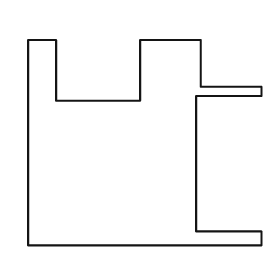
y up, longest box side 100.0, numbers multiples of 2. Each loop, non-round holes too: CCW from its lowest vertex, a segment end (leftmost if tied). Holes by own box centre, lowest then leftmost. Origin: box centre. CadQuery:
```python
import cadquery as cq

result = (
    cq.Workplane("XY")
    .moveTo(-50.0, -44.0)
    .lineTo(50.0, -44.0)
    .lineTo(50.0, -38.0)
    .lineTo(22.0, -38.0)
    .lineTo(22.0, 20.0)
    .lineTo(50.0, 20.0)
    .lineTo(50.0, 24.0)
    .lineTo(24.0, 24.0)
    .lineTo(24.0, 44.0)
    .lineTo(-2.0, 44.0)
    .lineTo(-2.0, 18.0)
    .lineTo(-38.0, 18.0)
    .lineTo(-38.0, 44.0)
    .lineTo(-50.0, 44.0)
    .close()
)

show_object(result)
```